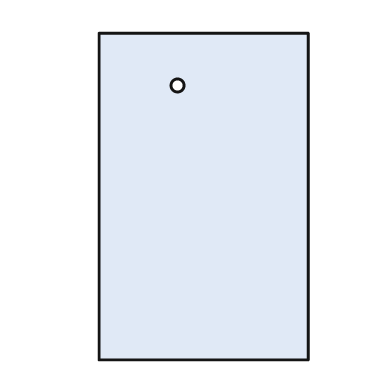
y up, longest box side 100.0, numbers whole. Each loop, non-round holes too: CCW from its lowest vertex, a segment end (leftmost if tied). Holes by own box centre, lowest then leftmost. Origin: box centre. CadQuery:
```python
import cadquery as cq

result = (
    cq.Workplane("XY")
    .moveTo(-32.0, -50.0)
    .lineTo(32.0, -50.0)
    .lineTo(32.0, 50.0)
    .lineTo(-32.0, 50.0)
    .close()
    .moveTo(-8.0, 34.0)
    .circle(2.0)
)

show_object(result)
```